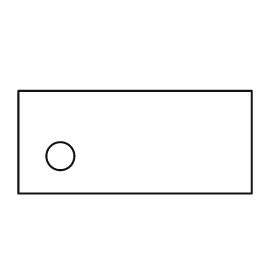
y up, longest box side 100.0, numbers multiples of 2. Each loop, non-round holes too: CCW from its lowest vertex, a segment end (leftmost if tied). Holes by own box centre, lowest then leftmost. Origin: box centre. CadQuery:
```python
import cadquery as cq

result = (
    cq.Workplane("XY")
    .moveTo(-50.0, -22.0)
    .lineTo(50.0, -22.0)
    .lineTo(50.0, 22.0)
    .lineTo(-50.0, 22.0)
    .close()
    .moveTo(-32.0, -6.0)
    .circle(6.0)
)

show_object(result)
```